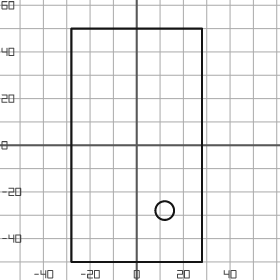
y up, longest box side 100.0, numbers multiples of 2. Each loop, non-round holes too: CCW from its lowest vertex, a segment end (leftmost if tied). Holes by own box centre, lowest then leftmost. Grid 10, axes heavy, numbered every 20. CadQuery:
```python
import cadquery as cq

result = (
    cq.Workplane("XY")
    .moveTo(-28.0, -50.0)
    .lineTo(28.0, -50.0)
    .lineTo(28.0, 50.0)
    .lineTo(-28.0, 50.0)
    .close()
    .moveTo(12.0, -28.0)
    .circle(4.0)
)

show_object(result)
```